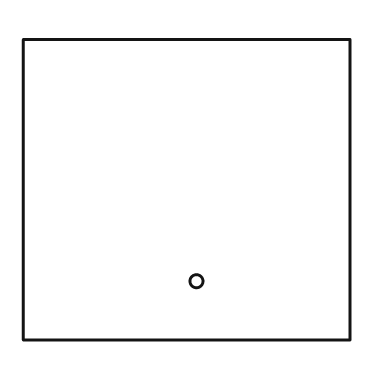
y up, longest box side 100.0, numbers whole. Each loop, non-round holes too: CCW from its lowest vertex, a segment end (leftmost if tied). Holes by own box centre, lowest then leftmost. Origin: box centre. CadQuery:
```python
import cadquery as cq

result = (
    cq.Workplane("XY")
    .moveTo(-50.0, -46.0)
    .lineTo(50.0, -46.0)
    .lineTo(50.0, 46.0)
    .lineTo(-50.0, 46.0)
    .close()
    .moveTo(3.0, -28.0)
    .circle(2.0)
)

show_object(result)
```